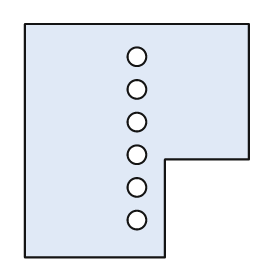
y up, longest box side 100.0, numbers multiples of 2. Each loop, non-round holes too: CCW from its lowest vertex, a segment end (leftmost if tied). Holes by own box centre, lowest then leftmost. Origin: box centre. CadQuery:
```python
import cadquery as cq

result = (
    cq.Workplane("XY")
    .moveTo(-48.0, -50.0)
    .lineTo(12.0, -50.0)
    .lineTo(12.0, -8.0)
    .lineTo(48.0, -8.0)
    .lineTo(48.0, 50.0)
    .lineTo(-48.0, 50.0)
    .close()
    .moveTo(0.0, -34.0)
    .circle(4.0)
    .moveTo(0.0, -20.0)
    .circle(4.0)
    .moveTo(0.0, -6.0)
    .circle(4.0)
    .moveTo(0.0, 8.0)
    .circle(4.0)
    .moveTo(0.0, 22.0)
    .circle(4.0)
    .moveTo(0.0, 36.0)
    .circle(4.0)
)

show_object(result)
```